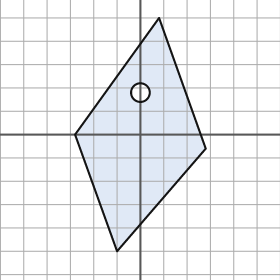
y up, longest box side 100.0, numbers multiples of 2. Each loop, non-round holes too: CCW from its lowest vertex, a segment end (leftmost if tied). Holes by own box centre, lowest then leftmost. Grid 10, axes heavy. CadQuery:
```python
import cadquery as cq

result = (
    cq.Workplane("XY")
    .moveTo(-10.0, -50.0)
    .lineTo(28.0, -6.0)
    .lineTo(8.0, 50.0)
    .lineTo(-28.0, 0.0)
    .close()
    .moveTo(0.0, 18.0)
    .circle(4.0)
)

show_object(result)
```